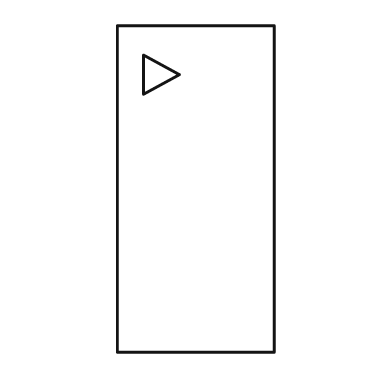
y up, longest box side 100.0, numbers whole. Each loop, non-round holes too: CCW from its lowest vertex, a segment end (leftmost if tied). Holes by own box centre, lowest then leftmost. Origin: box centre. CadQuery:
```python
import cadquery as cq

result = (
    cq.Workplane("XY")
    .moveTo(-24.0, -50.0)
    .lineTo(24.0, -50.0)
    .lineTo(24.0, 50.0)
    .lineTo(-24.0, 50.0)
    .close()
    .moveTo(-16.0, 29.0)
    .lineTo(-5.0, 35.0)
    .lineTo(-16.0, 41.0)
    .close()
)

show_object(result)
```